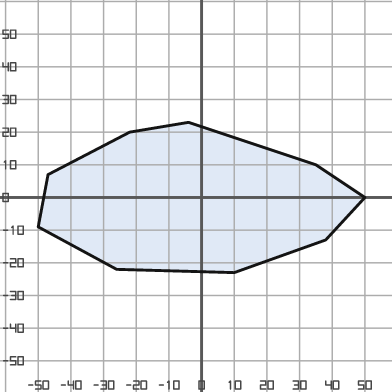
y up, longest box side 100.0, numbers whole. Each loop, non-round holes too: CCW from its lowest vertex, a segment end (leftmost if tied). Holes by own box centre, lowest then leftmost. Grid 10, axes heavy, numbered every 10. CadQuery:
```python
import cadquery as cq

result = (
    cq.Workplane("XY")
    .moveTo(10.0, -23.0)
    .lineTo(38.0, -13.0)
    .lineTo(50.0, 0.0)
    .lineTo(35.0, 10.0)
    .lineTo(-4.0, 23.0)
    .lineTo(-22.0, 20.0)
    .lineTo(-47.0, 7.0)
    .lineTo(-50.0, -9.0)
    .lineTo(-26.0, -22.0)
    .close()
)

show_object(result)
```